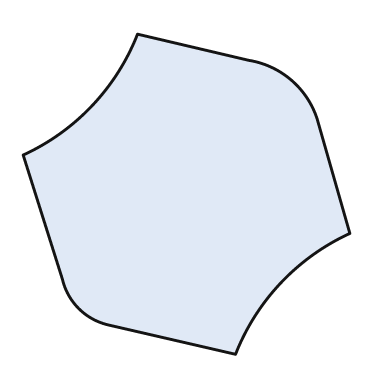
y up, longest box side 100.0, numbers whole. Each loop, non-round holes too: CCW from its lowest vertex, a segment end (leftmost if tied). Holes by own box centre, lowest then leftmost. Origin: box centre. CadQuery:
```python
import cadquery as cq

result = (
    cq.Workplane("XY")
    .moveTo(15.0, -49.0)
    .threePointArc((29.0, -27.0), (50.0, -12.0))
    .lineTo(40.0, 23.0)
    .threePointArc((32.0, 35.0), (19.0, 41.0))
    .lineTo(-15.0, 49.0)
    .threePointArc((-29.0, 27.0), (-50.0, 12.0))
    .lineTo(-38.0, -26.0)
    .threePointArc((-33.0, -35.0), (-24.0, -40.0))
    .close()
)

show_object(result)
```